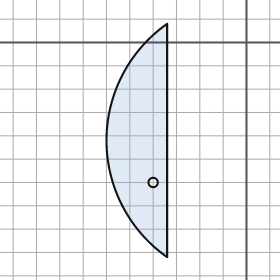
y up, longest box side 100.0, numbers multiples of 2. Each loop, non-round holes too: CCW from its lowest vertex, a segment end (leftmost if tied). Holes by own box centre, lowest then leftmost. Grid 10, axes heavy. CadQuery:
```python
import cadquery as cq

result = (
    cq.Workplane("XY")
    .moveTo(-34.0, -92.0)
    .lineTo(-34.0, 8.0)
    .threePointArc((-60.0, -42.0), (-34.0, -92.0))
    .close()
    .moveTo(-40.0, -60.0)
    .circle(2.0)
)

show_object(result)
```